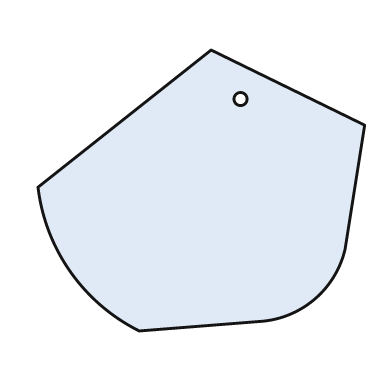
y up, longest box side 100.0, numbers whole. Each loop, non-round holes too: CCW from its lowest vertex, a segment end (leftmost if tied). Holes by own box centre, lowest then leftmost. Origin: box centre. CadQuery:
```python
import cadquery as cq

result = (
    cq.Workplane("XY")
    .moveTo(-19.0, -43.0)
    .lineTo(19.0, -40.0)
    .threePointArc((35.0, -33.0), (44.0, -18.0))
    .lineTo(50.0, 20.0)
    .lineTo(3.0, 43.0)
    .lineTo(-50.0, 1.0)
    .threePointArc((-40.0, -25.0), (-19.0, -43.0))
    .close()
    .moveTo(12.0, 28.0)
    .circle(2.0)
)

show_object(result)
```